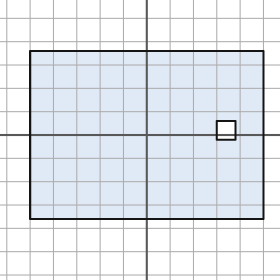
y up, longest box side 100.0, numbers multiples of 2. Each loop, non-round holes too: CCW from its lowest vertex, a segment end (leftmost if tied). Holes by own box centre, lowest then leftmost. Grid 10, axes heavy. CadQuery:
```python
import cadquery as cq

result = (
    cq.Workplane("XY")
    .moveTo(-50.0, -36.0)
    .lineTo(50.0, -36.0)
    .lineTo(50.0, 36.0)
    .lineTo(-50.0, 36.0)
    .close()
    .moveTo(30.0, -2.0)
    .lineTo(38.0, -2.0)
    .lineTo(38.0, 6.0)
    .lineTo(30.0, 6.0)
    .close()
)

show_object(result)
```